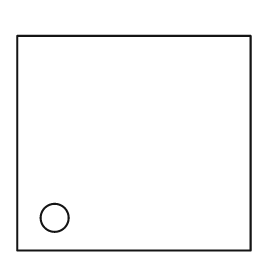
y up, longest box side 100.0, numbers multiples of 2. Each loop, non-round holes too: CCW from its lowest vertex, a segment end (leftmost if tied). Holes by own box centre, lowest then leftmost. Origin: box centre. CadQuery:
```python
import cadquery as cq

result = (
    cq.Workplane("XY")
    .moveTo(-50.0, -46.0)
    .lineTo(50.0, -46.0)
    .lineTo(50.0, 46.0)
    .lineTo(-50.0, 46.0)
    .close()
    .moveTo(-34.0, -32.0)
    .circle(6.0)
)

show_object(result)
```